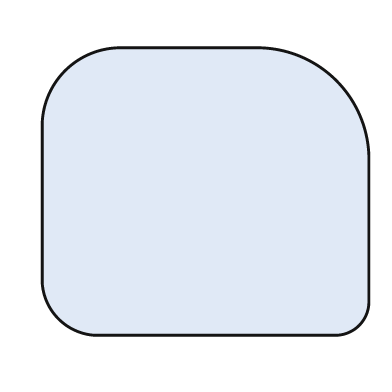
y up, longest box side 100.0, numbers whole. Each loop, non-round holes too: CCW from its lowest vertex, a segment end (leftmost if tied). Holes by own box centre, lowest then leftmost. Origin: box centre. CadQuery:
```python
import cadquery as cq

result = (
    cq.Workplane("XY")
    .moveTo(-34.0, -44.0)
    .lineTo(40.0, -44.0)
    .threePointArc((47.0, -41.0), (50.0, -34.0))
    .lineTo(50.0, 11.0)
    .threePointArc((40.0, 34.0), (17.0, 44.0))
    .lineTo(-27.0, 44.0)
    .threePointArc((-43.0, 37.0), (-50.0, 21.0))
    .lineTo(-50.0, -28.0)
    .threePointArc((-45.0, -39.0), (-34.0, -44.0))
    .close()
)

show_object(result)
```